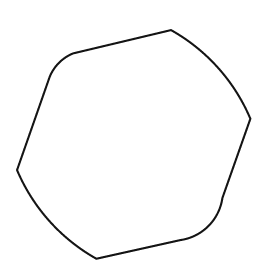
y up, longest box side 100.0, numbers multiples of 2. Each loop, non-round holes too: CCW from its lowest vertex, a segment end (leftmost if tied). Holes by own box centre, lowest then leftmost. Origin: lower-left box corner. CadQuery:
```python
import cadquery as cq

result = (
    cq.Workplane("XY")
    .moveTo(34.0, 0.0)
    .lineTo(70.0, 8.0)
    .threePointArc((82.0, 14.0), (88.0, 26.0))
    .lineTo(100.0, 60.0)
    .threePointArc((86.0, 82.0), (66.0, 98.0))
    .lineTo(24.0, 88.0)
    .threePointArc((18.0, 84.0), (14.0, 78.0))
    .lineTo(0.0, 38.0)
    .threePointArc((14.0, 16.0), (34.0, 0.0))
    .close()
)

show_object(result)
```